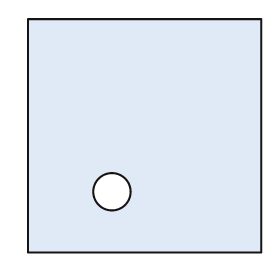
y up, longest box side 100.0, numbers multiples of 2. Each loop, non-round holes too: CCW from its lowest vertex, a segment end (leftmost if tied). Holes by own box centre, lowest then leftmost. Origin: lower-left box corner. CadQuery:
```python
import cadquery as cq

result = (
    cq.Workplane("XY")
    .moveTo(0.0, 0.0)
    .lineTo(100.0, 0.0)
    .lineTo(100.0, 100.0)
    .lineTo(0.0, 100.0)
    .close()
    .moveTo(36.0, 26.0)
    .circle(8.0)
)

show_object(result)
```